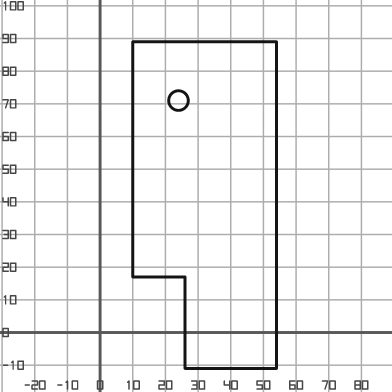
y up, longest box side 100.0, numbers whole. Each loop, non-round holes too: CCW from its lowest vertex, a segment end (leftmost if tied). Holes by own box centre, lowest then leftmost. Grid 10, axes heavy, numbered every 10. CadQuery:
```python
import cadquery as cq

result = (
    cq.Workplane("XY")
    .moveTo(26.0, -11.0)
    .lineTo(54.0, -11.0)
    .lineTo(54.0, 89.0)
    .lineTo(10.0, 89.0)
    .lineTo(10.0, 17.0)
    .lineTo(26.0, 17.0)
    .close()
    .moveTo(24.0, 71.0)
    .circle(3.0)
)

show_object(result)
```